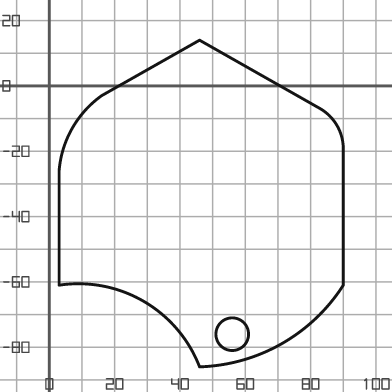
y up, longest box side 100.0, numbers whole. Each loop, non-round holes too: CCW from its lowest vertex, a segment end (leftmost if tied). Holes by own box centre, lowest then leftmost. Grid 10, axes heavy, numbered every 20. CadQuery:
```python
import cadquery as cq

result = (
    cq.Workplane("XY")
    .moveTo(46.0, -86.0)
    .threePointArc((71.0, -79.0), (90.0, -61.0))
    .lineTo(90.0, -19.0)
    .threePointArc((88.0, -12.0), (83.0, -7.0))
    .lineTo(46.0, 14.0)
    .lineTo(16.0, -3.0)
    .threePointArc((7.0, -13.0), (3.0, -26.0))
    .lineTo(3.0, -61.0)
    .threePointArc((29.0, -66.0), (46.0, -86.0))
    .close()
    .moveTo(56.0, -76.0)
    .circle(5.0)
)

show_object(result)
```